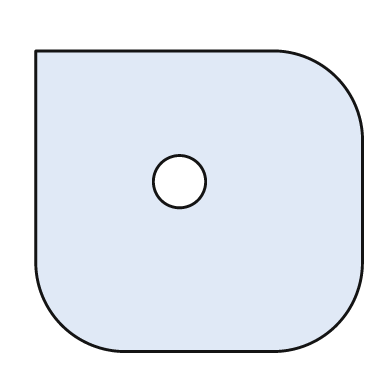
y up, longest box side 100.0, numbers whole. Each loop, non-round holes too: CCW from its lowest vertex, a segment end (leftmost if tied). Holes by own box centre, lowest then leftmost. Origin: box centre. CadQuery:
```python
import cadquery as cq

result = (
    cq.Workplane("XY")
    .moveTo(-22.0, -46.0)
    .lineTo(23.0, -46.0)
    .threePointArc((42.0, -38.0), (50.0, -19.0))
    .lineTo(50.0, 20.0)
    .threePointArc((42.0, 38.0), (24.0, 46.0))
    .lineTo(-50.0, 46.0)
    .lineTo(-50.0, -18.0)
    .threePointArc((-42.0, -38.0), (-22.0, -46.0))
    .close()
    .moveTo(-6.0, 6.0)
    .circle(8.0)
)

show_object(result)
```